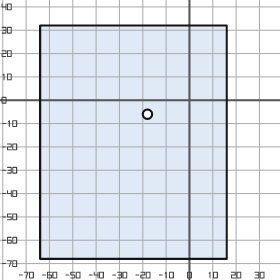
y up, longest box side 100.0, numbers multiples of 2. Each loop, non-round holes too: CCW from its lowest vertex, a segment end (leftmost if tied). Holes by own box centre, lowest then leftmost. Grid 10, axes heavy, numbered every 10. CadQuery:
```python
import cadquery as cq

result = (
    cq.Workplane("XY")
    .moveTo(-64.0, -68.0)
    .lineTo(16.0, -68.0)
    .lineTo(16.0, 32.0)
    .lineTo(-64.0, 32.0)
    .close()
    .moveTo(-18.0, -6.0)
    .circle(2.0)
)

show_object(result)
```